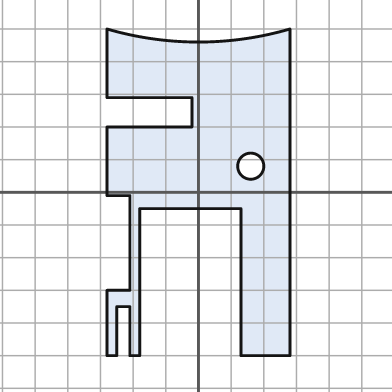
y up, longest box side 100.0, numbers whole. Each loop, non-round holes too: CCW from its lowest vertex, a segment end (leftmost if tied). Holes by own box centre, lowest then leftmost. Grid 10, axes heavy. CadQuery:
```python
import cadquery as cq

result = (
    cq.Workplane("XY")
    .moveTo(-28.0, -50.0)
    .lineTo(-25.0, -50.0)
    .lineTo(-25.0, -35.0)
    .lineTo(-21.0, -35.0)
    .lineTo(-21.0, -50.0)
    .lineTo(-18.0, -50.0)
    .lineTo(-18.0, -5.0)
    .lineTo(13.0, -5.0)
    .lineTo(13.0, -50.0)
    .lineTo(28.0, -50.0)
    .lineTo(28.0, 50.0)
    .threePointArc((0.0, 46.0), (-28.0, 50.0))
    .lineTo(-28.0, 29.0)
    .lineTo(-2.0, 29.0)
    .lineTo(-2.0, 20.0)
    .lineTo(-28.0, 20.0)
    .lineTo(-28.0, -1.0)
    .lineTo(-21.0, -1.0)
    .lineTo(-21.0, -30.0)
    .lineTo(-28.0, -30.0)
    .close()
    .moveTo(16.0, 8.0)
    .circle(4.0)
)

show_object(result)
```